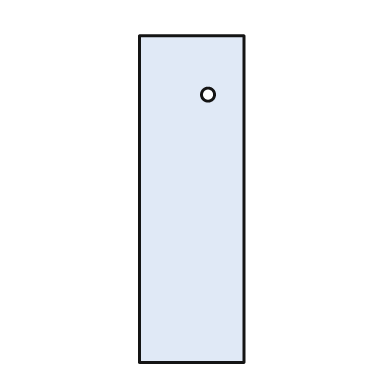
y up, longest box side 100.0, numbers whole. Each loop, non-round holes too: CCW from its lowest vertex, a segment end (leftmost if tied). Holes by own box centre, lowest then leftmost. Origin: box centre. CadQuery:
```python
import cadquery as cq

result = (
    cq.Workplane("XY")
    .moveTo(-16.0, -50.0)
    .lineTo(16.0, -50.0)
    .lineTo(16.0, 50.0)
    .lineTo(-16.0, 50.0)
    .close()
    .moveTo(5.0, 32.0)
    .circle(2.0)
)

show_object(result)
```